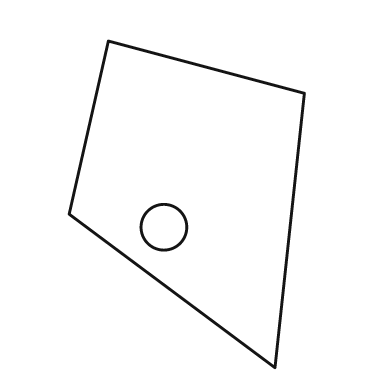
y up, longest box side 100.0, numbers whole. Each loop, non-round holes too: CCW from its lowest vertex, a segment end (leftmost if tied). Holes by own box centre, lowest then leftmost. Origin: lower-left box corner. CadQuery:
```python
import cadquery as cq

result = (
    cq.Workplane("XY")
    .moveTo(63.0, 0.0)
    .lineTo(72.0, 84.0)
    .lineTo(12.0, 100.0)
    .lineTo(0.0, 47.0)
    .close()
    .moveTo(29.0, 43.0)
    .circle(7.0)
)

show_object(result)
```